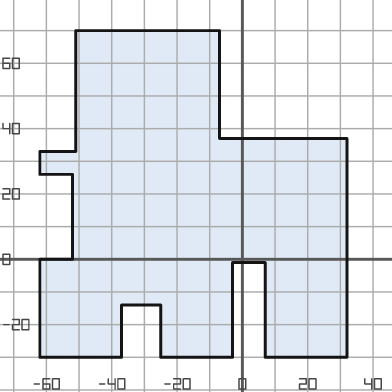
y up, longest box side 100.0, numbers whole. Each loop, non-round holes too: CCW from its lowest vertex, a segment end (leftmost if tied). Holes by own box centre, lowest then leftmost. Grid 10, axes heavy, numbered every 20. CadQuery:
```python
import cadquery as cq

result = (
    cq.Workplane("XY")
    .moveTo(-62.0, -30.0)
    .lineTo(-37.0, -30.0)
    .lineTo(-37.0, -14.0)
    .lineTo(-25.0, -14.0)
    .lineTo(-25.0, -30.0)
    .lineTo(-3.0, -30.0)
    .lineTo(-3.0, -1.0)
    .lineTo(7.0, -1.0)
    .lineTo(7.0, -30.0)
    .lineTo(32.0, -30.0)
    .lineTo(32.0, 37.0)
    .lineTo(-7.0, 37.0)
    .lineTo(-7.0, 70.0)
    .lineTo(-51.0, 70.0)
    .lineTo(-51.0, 33.0)
    .lineTo(-62.0, 33.0)
    .lineTo(-62.0, 26.0)
    .lineTo(-52.0, 26.0)
    .lineTo(-52.0, 0.0)
    .lineTo(-62.0, 0.0)
    .close()
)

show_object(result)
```